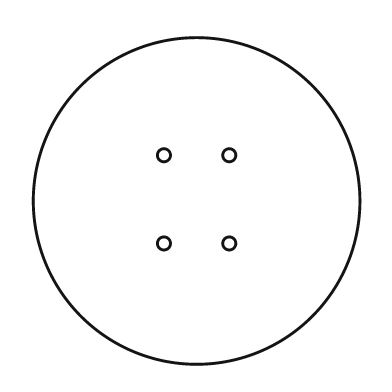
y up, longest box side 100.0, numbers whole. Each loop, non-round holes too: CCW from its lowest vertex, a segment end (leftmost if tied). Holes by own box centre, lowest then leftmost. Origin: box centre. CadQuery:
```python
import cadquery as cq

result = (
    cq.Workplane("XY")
    .moveTo(0.0, 0.0)
    .circle(50.0)
    .moveTo(-10.0, -13.0)
    .circle(2.0)
    .moveTo(10.0, -13.0)
    .circle(2.0)
    .moveTo(-10.0, 14.0)
    .circle(2.0)
    .moveTo(10.0, 14.0)
    .circle(2.0)
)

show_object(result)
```